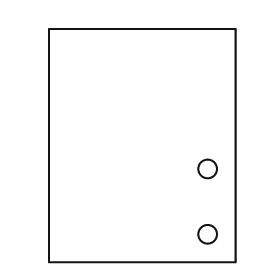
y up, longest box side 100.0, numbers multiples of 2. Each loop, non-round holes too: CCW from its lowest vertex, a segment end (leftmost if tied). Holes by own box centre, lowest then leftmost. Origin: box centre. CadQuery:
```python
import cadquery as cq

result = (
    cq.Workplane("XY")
    .moveTo(-40.0, -50.0)
    .lineTo(40.0, -50.0)
    .lineTo(40.0, 50.0)
    .lineTo(-40.0, 50.0)
    .close()
    .moveTo(28.0, -38.0)
    .circle(4.0)
    .moveTo(28.0, -10.0)
    .circle(4.0)
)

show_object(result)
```